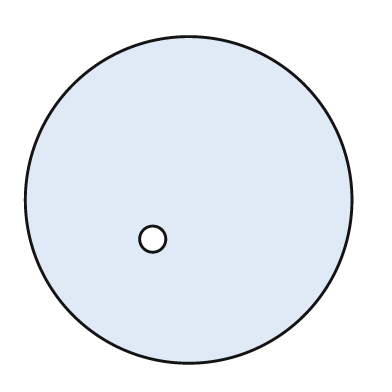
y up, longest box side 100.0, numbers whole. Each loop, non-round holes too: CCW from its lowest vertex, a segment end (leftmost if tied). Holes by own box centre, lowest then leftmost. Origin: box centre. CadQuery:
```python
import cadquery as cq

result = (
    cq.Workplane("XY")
    .moveTo(0.0, 0.0)
    .circle(50.0)
    .moveTo(-11.0, -12.0)
    .circle(4.0)
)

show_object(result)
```